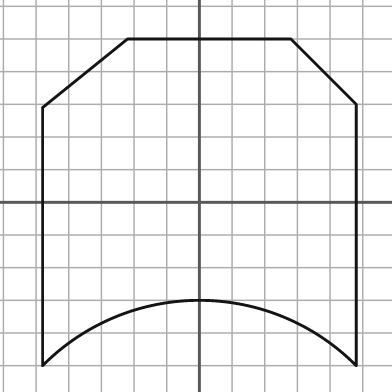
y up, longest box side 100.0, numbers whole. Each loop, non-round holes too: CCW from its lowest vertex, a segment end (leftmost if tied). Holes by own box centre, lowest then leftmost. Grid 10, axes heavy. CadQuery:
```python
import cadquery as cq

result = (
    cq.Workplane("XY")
    .moveTo(-48.0, -50.0)
    .threePointArc((0.0, -30.0), (48.0, -50.0))
    .lineTo(48.0, 30.0)
    .lineTo(28.0, 50.0)
    .lineTo(-22.0, 50.0)
    .lineTo(-48.0, 29.0)
    .close()
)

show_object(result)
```